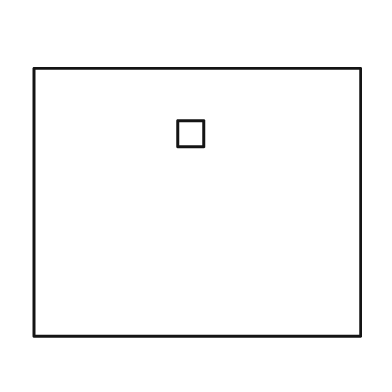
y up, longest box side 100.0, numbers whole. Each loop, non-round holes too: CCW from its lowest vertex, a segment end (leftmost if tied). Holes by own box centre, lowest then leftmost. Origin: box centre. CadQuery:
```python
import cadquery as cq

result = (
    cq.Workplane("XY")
    .moveTo(-50.0, -41.0)
    .lineTo(50.0, -41.0)
    .lineTo(50.0, 41.0)
    .lineTo(-50.0, 41.0)
    .close()
    .moveTo(-6.0, 17.0)
    .lineTo(2.0, 17.0)
    .lineTo(2.0, 25.0)
    .lineTo(-6.0, 25.0)
    .close()
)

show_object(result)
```